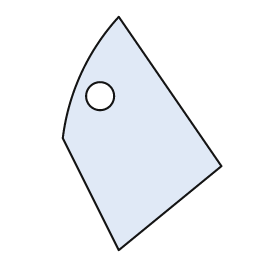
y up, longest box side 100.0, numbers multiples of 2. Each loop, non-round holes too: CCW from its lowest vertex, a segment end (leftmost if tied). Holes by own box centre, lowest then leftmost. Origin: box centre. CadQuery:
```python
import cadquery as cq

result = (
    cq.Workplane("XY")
    .moveTo(-10.0, -50.0)
    .lineTo(34.0, -14.0)
    .lineTo(-10.0, 50.0)
    .threePointArc((-26.0, 26.0), (-34.0, -2.0))
    .close()
    .moveTo(-18.0, 16.0)
    .circle(6.0)
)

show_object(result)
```